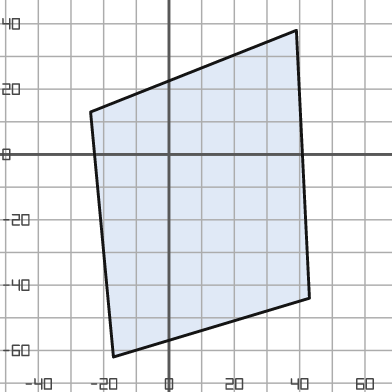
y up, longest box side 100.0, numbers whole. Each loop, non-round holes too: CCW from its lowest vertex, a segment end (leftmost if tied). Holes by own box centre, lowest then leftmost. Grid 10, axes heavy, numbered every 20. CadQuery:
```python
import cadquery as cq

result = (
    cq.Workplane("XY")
    .moveTo(-17.0, -62.0)
    .lineTo(43.0, -44.0)
    .lineTo(39.0, 38.0)
    .lineTo(-24.0, 13.0)
    .close()
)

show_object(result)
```